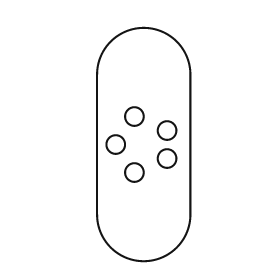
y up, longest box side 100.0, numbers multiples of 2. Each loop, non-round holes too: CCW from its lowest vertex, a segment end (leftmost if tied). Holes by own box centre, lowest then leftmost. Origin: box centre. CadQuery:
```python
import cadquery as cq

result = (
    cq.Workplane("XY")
    .moveTo(-20.0, -30.0)
    .threePointArc((0.0, -50.0), (20.0, -30.0))
    .lineTo(20.0, 30.0)
    .threePointArc((0.0, 50.0), (-20.0, 30.0))
    .close()
    .moveTo(-4.0, -12.0)
    .circle(4.0)
    .moveTo(10.0, -6.0)
    .circle(4.0)
    .moveTo(-12.0, 0.0)
    .circle(4.0)
    .moveTo(10.0, 6.0)
    .circle(4.0)
    .moveTo(-4.0, 12.0)
    .circle(4.0)
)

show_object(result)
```